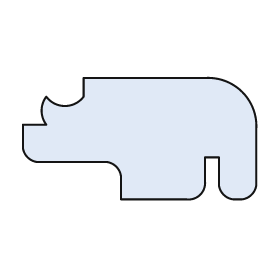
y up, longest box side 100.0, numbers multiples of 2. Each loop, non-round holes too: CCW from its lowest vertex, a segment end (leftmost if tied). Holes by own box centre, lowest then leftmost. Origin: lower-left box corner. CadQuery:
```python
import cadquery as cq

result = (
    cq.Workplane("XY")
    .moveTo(42.0, 0.0)
    .lineTo(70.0, 0.0)
    .threePointArc((76.0, 2.0), (78.0, 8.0))
    .lineTo(78.0, 18.0)
    .lineTo(84.0, 18.0)
    .lineTo(84.0, 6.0)
    .threePointArc((86.0, 2.0), (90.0, 0.0))
    .lineTo(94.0, 0.0)
    .threePointArc((98.0, 2.0), (100.0, 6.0))
    .lineTo(100.0, 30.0)
    .threePointArc((94.0, 46.0), (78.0, 52.0))
    .lineTo(26.0, 52.0)
    .lineTo(26.0, 44.0)
    .threePointArc((18.0, 40.0), (10.0, 44.0))
    .threePointArc((8.0, 38.0), (10.0, 32.0))
    .lineTo(0.0, 32.0)
    .lineTo(0.0, 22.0)
    .threePointArc((2.0, 18.0), (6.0, 16.0))
    .lineTo(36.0, 16.0)
    .threePointArc((40.0, 14.0), (42.0, 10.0))
    .close()
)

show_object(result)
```